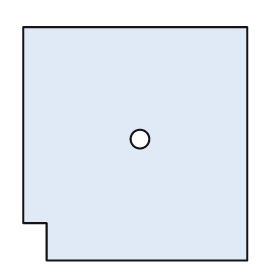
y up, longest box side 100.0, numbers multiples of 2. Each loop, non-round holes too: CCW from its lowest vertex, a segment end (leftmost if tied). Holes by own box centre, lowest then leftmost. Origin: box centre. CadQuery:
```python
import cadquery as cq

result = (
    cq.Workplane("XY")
    .moveTo(-38.0, -50.0)
    .lineTo(48.0, -50.0)
    .lineTo(48.0, 50.0)
    .lineTo(-48.0, 50.0)
    .lineTo(-48.0, -34.0)
    .lineTo(-38.0, -34.0)
    .close()
    .moveTo(2.0, 2.0)
    .circle(4.0)
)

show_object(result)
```